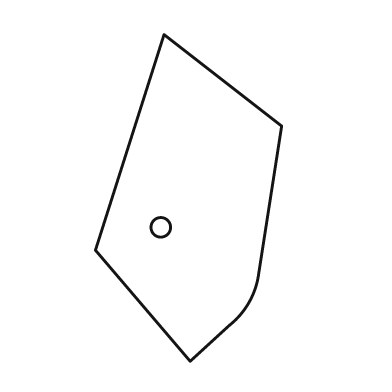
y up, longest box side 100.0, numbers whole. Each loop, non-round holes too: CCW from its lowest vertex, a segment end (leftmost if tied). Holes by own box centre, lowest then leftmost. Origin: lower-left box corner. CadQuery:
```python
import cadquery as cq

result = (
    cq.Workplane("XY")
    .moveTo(29.0, 0.0)
    .lineTo(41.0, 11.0)
    .threePointArc((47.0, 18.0), (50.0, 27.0))
    .lineTo(57.0, 72.0)
    .lineTo(21.0, 100.0)
    .lineTo(0.0, 34.0)
    .close()
    .moveTo(20.0, 41.0)
    .circle(3.0)
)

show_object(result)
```